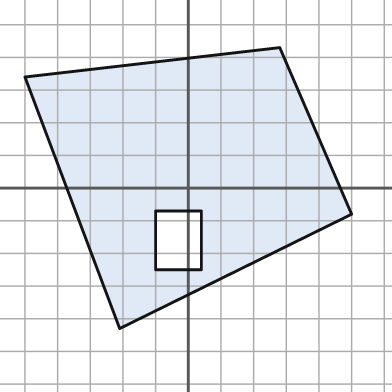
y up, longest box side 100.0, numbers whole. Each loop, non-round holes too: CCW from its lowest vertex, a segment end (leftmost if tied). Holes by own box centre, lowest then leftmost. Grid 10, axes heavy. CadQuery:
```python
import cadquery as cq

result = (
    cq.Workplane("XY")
    .moveTo(-21.0, -43.0)
    .lineTo(50.0, -8.0)
    .lineTo(28.0, 43.0)
    .lineTo(-50.0, 34.0)
    .close()
    .moveTo(-10.0, -25.0)
    .lineTo(4.0, -25.0)
    .lineTo(4.0, -7.0)
    .lineTo(-10.0, -7.0)
    .close()
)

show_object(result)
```